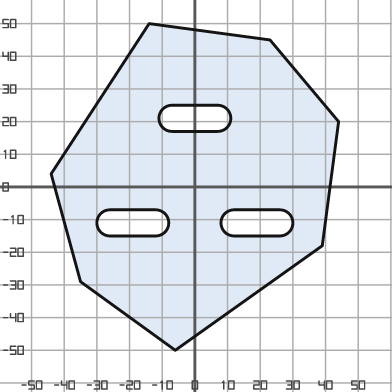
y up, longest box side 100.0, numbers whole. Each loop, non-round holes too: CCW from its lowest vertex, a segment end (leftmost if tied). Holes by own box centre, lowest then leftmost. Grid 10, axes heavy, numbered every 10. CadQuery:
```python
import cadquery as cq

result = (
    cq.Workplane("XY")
    .moveTo(-6.0, -50.0)
    .lineTo(39.0, -18.0)
    .lineTo(44.0, 20.0)
    .lineTo(23.0, 45.0)
    .lineTo(-14.0, 50.0)
    .lineTo(-44.0, 4.0)
    .lineTo(-35.0, -29.0)
    .close()
    .moveTo(-26.0, -15.0)
    .lineTo(-12.0, -15.0)
    .threePointArc((-8.0, -11.0), (-12.0, -7.0))
    .lineTo(-26.0, -7.0)
    .threePointArc((-30.0, -11.0), (-26.0, -15.0))
    .close()
    .moveTo(12.0, -15.0)
    .lineTo(26.0, -15.0)
    .threePointArc((30.0, -11.0), (26.0, -7.0))
    .lineTo(12.0, -7.0)
    .threePointArc((8.0, -11.0), (12.0, -15.0))
    .close()
    .moveTo(-7.0, 17.0)
    .lineTo(7.0, 17.0)
    .threePointArc((11.0, 21.0), (7.0, 25.0))
    .lineTo(-7.0, 25.0)
    .threePointArc((-11.0, 21.0), (-7.0, 17.0))
    .close()
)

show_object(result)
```